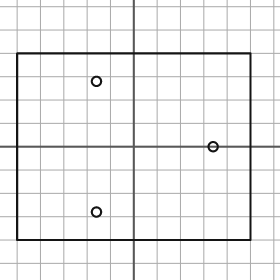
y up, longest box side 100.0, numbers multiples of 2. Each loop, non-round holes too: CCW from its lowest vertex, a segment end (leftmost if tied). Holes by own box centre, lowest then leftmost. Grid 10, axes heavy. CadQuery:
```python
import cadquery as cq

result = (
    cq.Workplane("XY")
    .moveTo(-50.0, -40.0)
    .lineTo(50.0, -40.0)
    .lineTo(50.0, 40.0)
    .lineTo(-50.0, 40.0)
    .close()
    .moveTo(-16.0, -28.0)
    .circle(2.0)
    .moveTo(34.0, 0.0)
    .circle(2.0)
    .moveTo(-16.0, 28.0)
    .circle(2.0)
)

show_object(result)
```